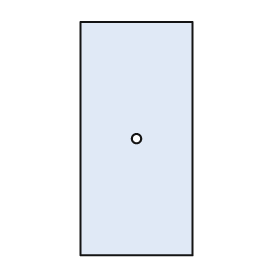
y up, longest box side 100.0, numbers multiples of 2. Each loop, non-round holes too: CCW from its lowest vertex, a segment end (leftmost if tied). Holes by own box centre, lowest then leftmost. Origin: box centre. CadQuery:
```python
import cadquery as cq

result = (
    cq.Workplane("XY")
    .moveTo(-24.0, -50.0)
    .lineTo(24.0, -50.0)
    .lineTo(24.0, 50.0)
    .lineTo(-24.0, 50.0)
    .close()
    .moveTo(0.0, 0.0)
    .circle(2.0)
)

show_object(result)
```